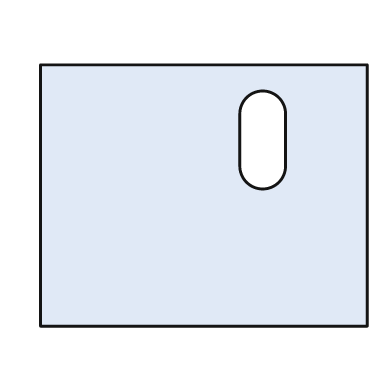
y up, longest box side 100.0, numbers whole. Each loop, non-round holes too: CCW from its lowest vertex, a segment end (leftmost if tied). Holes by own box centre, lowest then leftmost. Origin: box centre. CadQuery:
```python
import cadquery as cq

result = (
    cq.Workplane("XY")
    .moveTo(-50.0, -40.0)
    .lineTo(50.0, -40.0)
    .lineTo(50.0, 40.0)
    .lineTo(-50.0, 40.0)
    .close()
    .moveTo(11.0, 9.0)
    .threePointArc((18.0, 2.0), (25.0, 9.0))
    .lineTo(25.0, 25.0)
    .threePointArc((18.0, 32.0), (11.0, 25.0))
    .close()
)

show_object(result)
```